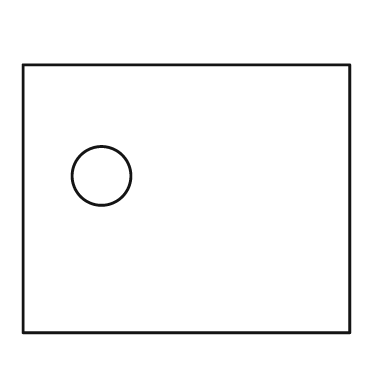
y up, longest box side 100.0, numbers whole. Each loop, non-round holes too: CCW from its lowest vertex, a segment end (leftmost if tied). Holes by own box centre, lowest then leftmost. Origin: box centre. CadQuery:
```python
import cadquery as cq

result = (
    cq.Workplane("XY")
    .moveTo(-50.0, -41.0)
    .lineTo(50.0, -41.0)
    .lineTo(50.0, 41.0)
    .lineTo(-50.0, 41.0)
    .close()
    .moveTo(-26.0, 7.0)
    .circle(9.0)
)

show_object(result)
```